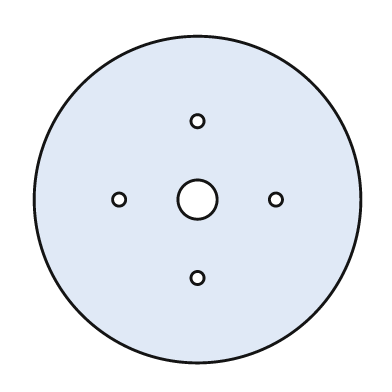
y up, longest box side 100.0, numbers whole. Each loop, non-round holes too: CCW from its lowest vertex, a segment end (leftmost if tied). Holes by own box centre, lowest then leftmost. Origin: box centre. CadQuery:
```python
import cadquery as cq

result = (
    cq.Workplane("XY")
    .moveTo(0.0, 0.0)
    .circle(50.0)
    .moveTo(0.0, -24.0)
    .circle(2.0)
    .moveTo(-24.0, 0.0)
    .circle(2.0)
    .moveTo(0.0, 0.0)
    .circle(6.0)
    .moveTo(24.0, 0.0)
    .circle(2.0)
    .moveTo(0.0, 24.0)
    .circle(2.0)
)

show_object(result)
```